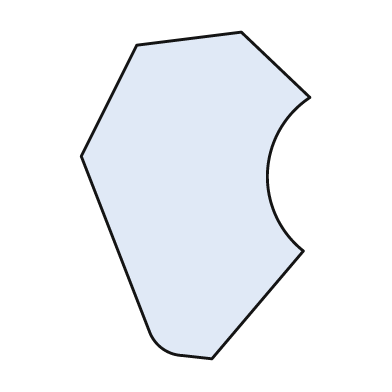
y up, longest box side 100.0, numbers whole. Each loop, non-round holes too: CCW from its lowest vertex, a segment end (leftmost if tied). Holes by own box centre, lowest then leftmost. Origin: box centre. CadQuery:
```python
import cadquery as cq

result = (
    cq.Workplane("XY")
    .moveTo(5.0, -50.0)
    .lineTo(33.0, -17.0)
    .threePointArc((22.0, 7.0), (35.0, 30.0))
    .lineTo(14.0, 50.0)
    .lineTo(-18.0, 46.0)
    .lineTo(-35.0, 12.0)
    .lineTo(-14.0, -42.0)
    .threePointArc((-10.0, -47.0), (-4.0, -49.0))
    .close()
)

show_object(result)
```